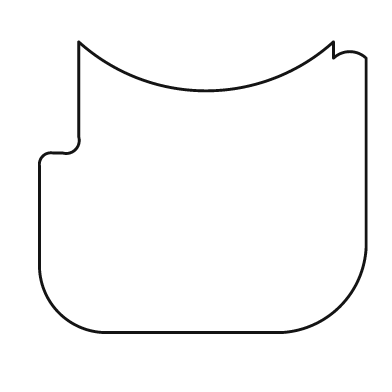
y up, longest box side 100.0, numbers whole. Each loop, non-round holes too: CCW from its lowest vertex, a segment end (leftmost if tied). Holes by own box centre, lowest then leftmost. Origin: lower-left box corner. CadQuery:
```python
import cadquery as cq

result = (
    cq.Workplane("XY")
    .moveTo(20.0, 0.0)
    .lineTo(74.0, 0.0)
    .threePointArc((92.0, 8.0), (100.0, 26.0))
    .lineTo(100.0, 84.0)
    .threePointArc((95.0, 86.0), (90.0, 84.0))
    .lineTo(90.0, 89.0)
    .threePointArc((51.0, 74.0), (12.0, 89.0))
    .lineTo(12.0, 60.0)
    .threePointArc((11.0, 56.0), (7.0, 55.0))
    .lineTo(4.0, 55.0)
    .threePointArc((1.0, 54.0), (0.0, 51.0))
    .lineTo(0.0, 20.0)
    .threePointArc((6.0, 6.0), (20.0, 0.0))
    .close()
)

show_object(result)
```